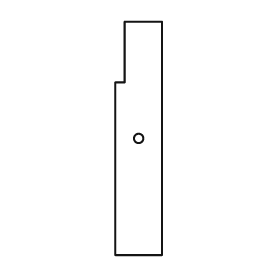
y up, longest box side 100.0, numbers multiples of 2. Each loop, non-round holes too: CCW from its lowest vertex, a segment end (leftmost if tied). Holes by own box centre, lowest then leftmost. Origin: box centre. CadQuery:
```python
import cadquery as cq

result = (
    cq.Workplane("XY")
    .moveTo(-10.0, -50.0)
    .lineTo(10.0, -50.0)
    .lineTo(10.0, 50.0)
    .lineTo(-6.0, 50.0)
    .lineTo(-6.0, 24.0)
    .lineTo(-10.0, 24.0)
    .close()
    .moveTo(0.0, 0.0)
    .circle(2.0)
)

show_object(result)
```